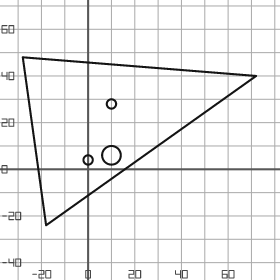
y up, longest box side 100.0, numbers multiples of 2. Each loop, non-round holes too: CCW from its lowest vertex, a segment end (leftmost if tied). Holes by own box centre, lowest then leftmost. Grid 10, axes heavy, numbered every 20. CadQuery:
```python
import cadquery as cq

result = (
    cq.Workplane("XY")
    .moveTo(-18.0, -24.0)
    .lineTo(72.0, 40.0)
    .lineTo(-28.0, 48.0)
    .close()
    .moveTo(0.0, 4.0)
    .circle(2.0)
    .moveTo(10.0, 6.0)
    .circle(4.0)
    .moveTo(10.0, 28.0)
    .circle(2.0)
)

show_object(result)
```